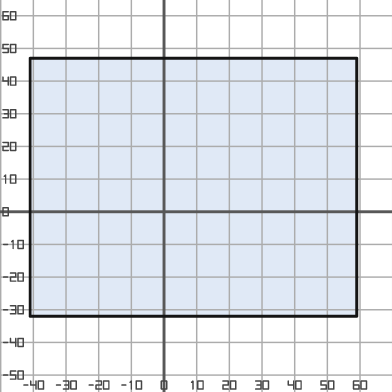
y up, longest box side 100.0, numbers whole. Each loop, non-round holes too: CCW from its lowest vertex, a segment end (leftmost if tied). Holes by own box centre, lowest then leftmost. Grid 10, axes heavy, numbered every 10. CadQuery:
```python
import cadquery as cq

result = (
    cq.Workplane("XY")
    .moveTo(-41.0, -32.0)
    .lineTo(59.0, -32.0)
    .lineTo(59.0, 47.0)
    .lineTo(-41.0, 47.0)
    .close()
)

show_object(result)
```